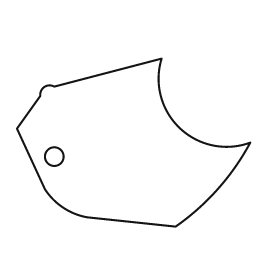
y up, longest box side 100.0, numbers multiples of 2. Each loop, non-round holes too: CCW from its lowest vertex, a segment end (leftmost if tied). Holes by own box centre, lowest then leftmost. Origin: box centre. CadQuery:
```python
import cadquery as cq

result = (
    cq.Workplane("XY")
    .moveTo(18.0, -36.0)
    .threePointArc((36.0, -20.0), (50.0, 0.0))
    .threePointArc((20.0, 6.0), (12.0, 36.0))
    .lineTo(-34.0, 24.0)
    .threePointArc((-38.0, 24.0), (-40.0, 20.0))
    .lineTo(-50.0, 6.0)
    .lineTo(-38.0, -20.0)
    .threePointArc((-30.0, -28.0), (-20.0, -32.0))
    .close()
    .moveTo(-34.0, -6.0)
    .circle(4.0)
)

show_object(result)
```